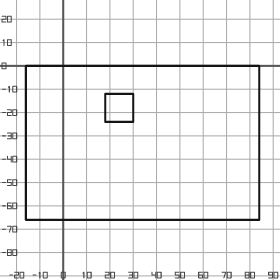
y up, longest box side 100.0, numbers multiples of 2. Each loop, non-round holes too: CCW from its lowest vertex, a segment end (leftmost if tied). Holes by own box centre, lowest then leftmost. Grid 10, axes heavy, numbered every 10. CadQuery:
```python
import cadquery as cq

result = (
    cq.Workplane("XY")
    .moveTo(-16.0, -66.0)
    .lineTo(84.0, -66.0)
    .lineTo(84.0, 0.0)
    .lineTo(-16.0, 0.0)
    .close()
    .moveTo(18.0, -24.0)
    .lineTo(30.0, -24.0)
    .lineTo(30.0, -12.0)
    .lineTo(18.0, -12.0)
    .close()
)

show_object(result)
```